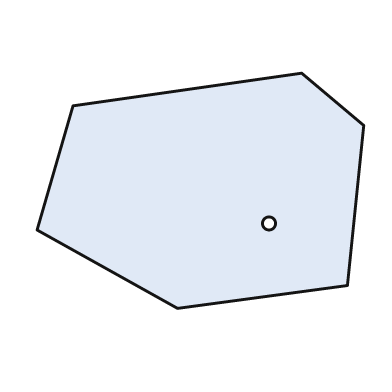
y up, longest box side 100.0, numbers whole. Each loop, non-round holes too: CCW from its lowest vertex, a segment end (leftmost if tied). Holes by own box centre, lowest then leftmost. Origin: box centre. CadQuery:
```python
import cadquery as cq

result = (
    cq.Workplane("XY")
    .moveTo(-7.0, -36.0)
    .lineTo(45.0, -29.0)
    .lineTo(50.0, 20.0)
    .lineTo(31.0, 36.0)
    .lineTo(-39.0, 26.0)
    .lineTo(-50.0, -12.0)
    .close()
    .moveTo(21.0, -10.0)
    .circle(2.0)
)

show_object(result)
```